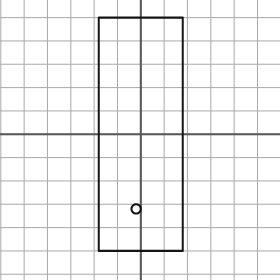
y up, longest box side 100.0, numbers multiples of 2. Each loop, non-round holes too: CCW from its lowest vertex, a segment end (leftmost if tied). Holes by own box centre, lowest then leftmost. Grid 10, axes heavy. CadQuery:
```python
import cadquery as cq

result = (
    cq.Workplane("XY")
    .moveTo(-18.0, -50.0)
    .lineTo(18.0, -50.0)
    .lineTo(18.0, 50.0)
    .lineTo(-18.0, 50.0)
    .close()
    .moveTo(-2.0, -32.0)
    .circle(2.0)
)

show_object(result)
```